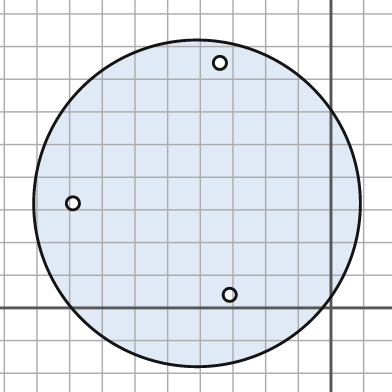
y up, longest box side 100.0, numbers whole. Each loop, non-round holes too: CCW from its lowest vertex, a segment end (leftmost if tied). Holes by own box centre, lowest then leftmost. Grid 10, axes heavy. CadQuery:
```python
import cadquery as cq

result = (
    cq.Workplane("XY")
    .moveTo(-41.0, 32.0)
    .circle(50.0)
    .moveTo(-31.0, 4.0)
    .circle(2.0)
    .moveTo(-79.0, 32.0)
    .circle(2.0)
    .moveTo(-34.0, 75.0)
    .circle(2.0)
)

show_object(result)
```